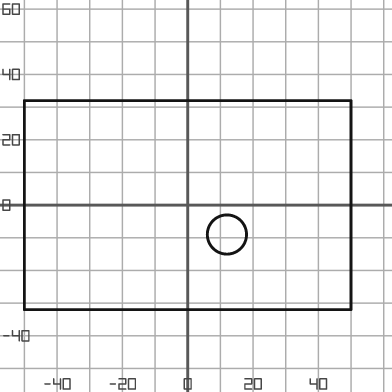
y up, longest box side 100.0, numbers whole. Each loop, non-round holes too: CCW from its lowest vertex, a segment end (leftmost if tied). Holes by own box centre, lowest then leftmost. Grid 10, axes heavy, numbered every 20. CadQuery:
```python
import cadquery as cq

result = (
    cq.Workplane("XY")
    .moveTo(-50.0, -32.0)
    .lineTo(50.0, -32.0)
    .lineTo(50.0, 32.0)
    .lineTo(-50.0, 32.0)
    .close()
    .moveTo(12.0, -9.0)
    .circle(6.0)
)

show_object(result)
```